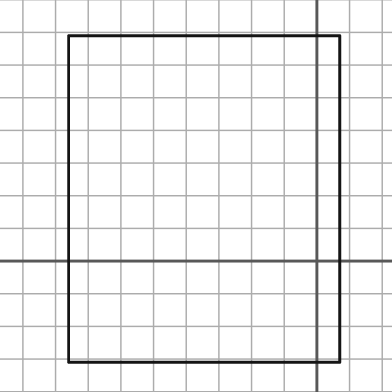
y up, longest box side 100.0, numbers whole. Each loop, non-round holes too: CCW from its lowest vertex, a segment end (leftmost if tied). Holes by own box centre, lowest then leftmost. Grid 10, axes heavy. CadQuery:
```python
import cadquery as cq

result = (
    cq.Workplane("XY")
    .moveTo(-76.0, -31.0)
    .lineTo(7.0, -31.0)
    .lineTo(7.0, 69.0)
    .lineTo(-76.0, 69.0)
    .close()
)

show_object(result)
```